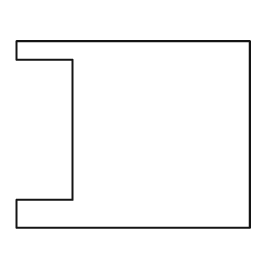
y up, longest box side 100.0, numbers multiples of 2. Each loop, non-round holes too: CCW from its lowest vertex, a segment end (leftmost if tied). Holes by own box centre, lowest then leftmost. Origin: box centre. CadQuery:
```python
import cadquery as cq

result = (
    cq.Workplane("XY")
    .moveTo(-50.0, -40.0)
    .lineTo(50.0, -40.0)
    .lineTo(50.0, 40.0)
    .lineTo(-50.0, 40.0)
    .lineTo(-50.0, 32.0)
    .lineTo(-26.0, 32.0)
    .lineTo(-26.0, -28.0)
    .lineTo(-50.0, -28.0)
    .close()
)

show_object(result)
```